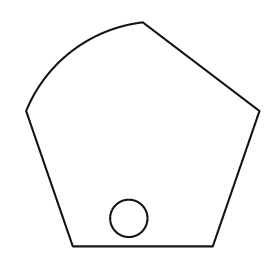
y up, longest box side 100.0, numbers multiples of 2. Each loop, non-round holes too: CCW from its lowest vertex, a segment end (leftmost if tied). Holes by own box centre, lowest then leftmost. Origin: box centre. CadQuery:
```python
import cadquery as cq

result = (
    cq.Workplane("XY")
    .moveTo(-30.0, -48.0)
    .lineTo(30.0, -48.0)
    .lineTo(50.0, 10.0)
    .lineTo(0.0, 48.0)
    .threePointArc((-30.0, 36.0), (-50.0, 10.0))
    .close()
    .moveTo(-6.0, -36.0)
    .circle(8.0)
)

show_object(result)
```